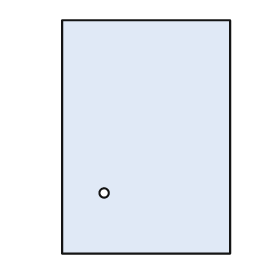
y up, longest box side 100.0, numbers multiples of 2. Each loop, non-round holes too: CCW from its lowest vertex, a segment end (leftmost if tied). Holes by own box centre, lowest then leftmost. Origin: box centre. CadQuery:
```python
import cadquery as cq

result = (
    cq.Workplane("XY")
    .moveTo(-36.0, -50.0)
    .lineTo(36.0, -50.0)
    .lineTo(36.0, 50.0)
    .lineTo(-36.0, 50.0)
    .close()
    .moveTo(-18.0, -24.0)
    .circle(2.0)
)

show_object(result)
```